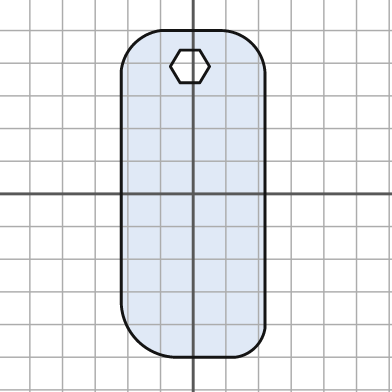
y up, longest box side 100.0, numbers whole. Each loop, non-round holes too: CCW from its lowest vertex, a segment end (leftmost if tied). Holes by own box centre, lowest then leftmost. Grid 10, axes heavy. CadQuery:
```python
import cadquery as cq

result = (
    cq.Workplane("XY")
    .moveTo(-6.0, -50.0)
    .lineTo(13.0, -50.0)
    .threePointArc((19.0, -47.0), (22.0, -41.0))
    .lineTo(22.0, 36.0)
    .threePointArc((18.0, 46.0), (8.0, 50.0))
    .lineTo(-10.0, 50.0)
    .threePointArc((-18.0, 46.0), (-22.0, 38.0))
    .lineTo(-22.0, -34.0)
    .threePointArc((-17.0, -45.0), (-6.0, -50.0))
    .close()
    .moveTo(-4.0, 34.0)
    .lineTo(2.0, 34.0)
    .lineTo(5.0, 39.0)
    .lineTo(2.0, 44.0)
    .lineTo(-4.0, 44.0)
    .lineTo(-7.0, 39.0)
    .close()
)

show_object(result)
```